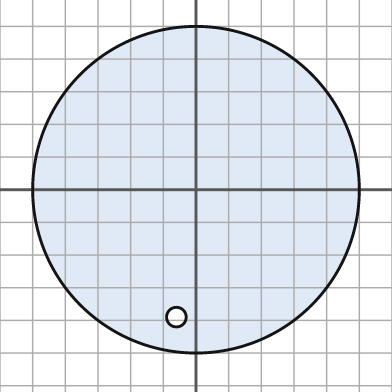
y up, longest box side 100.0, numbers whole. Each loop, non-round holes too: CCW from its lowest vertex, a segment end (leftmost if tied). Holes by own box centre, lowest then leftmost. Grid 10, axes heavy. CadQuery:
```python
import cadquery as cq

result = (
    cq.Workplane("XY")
    .moveTo(0.0, 0.0)
    .circle(50.0)
    .moveTo(-6.0, -39.0)
    .circle(3.0)
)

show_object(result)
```